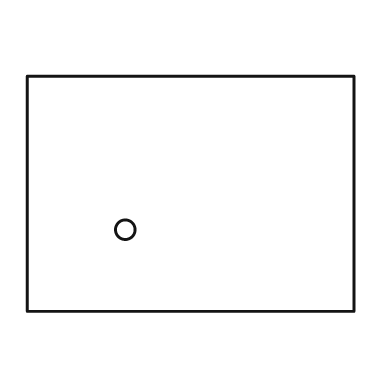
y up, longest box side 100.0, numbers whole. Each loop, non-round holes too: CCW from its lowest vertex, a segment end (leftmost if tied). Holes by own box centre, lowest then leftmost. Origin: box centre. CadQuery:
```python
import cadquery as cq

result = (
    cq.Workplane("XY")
    .moveTo(-50.0, -36.0)
    .lineTo(50.0, -36.0)
    .lineTo(50.0, 36.0)
    .lineTo(-50.0, 36.0)
    .close()
    .moveTo(-20.0, -11.0)
    .circle(3.0)
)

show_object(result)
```